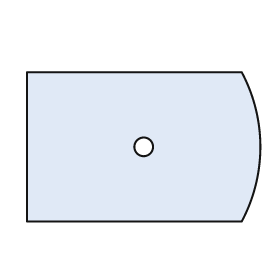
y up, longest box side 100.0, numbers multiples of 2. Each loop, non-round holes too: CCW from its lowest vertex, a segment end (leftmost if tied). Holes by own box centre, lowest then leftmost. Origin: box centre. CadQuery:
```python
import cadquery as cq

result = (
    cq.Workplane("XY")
    .moveTo(-50.0, -32.0)
    .lineTo(42.0, -32.0)
    .threePointArc((50.0, 0.0), (42.0, 32.0))
    .lineTo(-50.0, 32.0)
    .close()
    .moveTo(0.0, 0.0)
    .circle(4.0)
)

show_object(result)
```